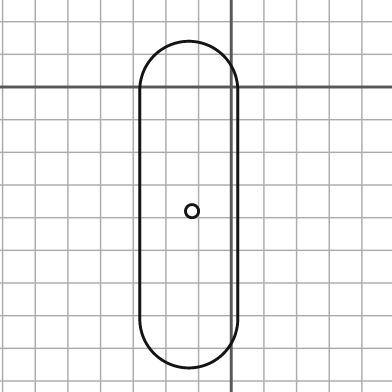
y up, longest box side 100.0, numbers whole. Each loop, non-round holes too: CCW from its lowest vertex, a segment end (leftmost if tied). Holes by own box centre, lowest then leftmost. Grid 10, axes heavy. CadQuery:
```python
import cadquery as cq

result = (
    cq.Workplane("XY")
    .moveTo(-28.0, -71.0)
    .threePointArc((-13.0, -86.0), (2.0, -71.0))
    .lineTo(2.0, -1.0)
    .threePointArc((-13.0, 14.0), (-28.0, -1.0))
    .close()
    .moveTo(-12.0, -38.0)
    .circle(2.0)
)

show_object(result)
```